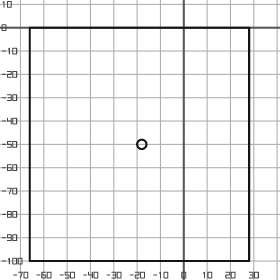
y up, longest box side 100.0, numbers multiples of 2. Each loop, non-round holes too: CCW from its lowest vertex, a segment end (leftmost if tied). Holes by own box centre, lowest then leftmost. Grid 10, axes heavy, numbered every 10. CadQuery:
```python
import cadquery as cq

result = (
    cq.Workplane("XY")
    .moveTo(-66.0, -100.0)
    .lineTo(28.0, -100.0)
    .lineTo(28.0, 0.0)
    .lineTo(-66.0, 0.0)
    .close()
    .moveTo(-18.0, -50.0)
    .circle(2.0)
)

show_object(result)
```